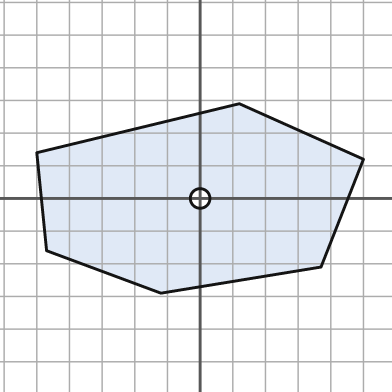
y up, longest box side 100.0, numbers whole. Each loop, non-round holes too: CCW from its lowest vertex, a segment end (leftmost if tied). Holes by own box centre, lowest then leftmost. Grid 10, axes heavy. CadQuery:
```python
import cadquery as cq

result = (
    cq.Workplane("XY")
    .moveTo(-12.0, -29.0)
    .lineTo(37.0, -21.0)
    .lineTo(50.0, 12.0)
    .lineTo(12.0, 29.0)
    .lineTo(-50.0, 14.0)
    .lineTo(-47.0, -16.0)
    .close()
    .moveTo(0.0, 0.0)
    .circle(3.0)
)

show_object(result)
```